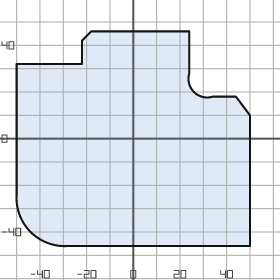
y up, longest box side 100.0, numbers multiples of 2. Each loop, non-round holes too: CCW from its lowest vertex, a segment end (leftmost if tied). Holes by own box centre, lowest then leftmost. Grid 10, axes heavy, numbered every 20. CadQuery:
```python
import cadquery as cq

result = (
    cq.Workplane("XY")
    .moveTo(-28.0, -46.0)
    .lineTo(50.0, -46.0)
    .lineTo(50.0, 10.0)
    .lineTo(44.0, 18.0)
    .lineTo(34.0, 18.0)
    .threePointArc((26.0, 20.0), (24.0, 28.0))
    .lineTo(24.0, 46.0)
    .lineTo(-18.0, 46.0)
    .lineTo(-22.0, 42.0)
    .lineTo(-22.0, 32.0)
    .lineTo(-50.0, 32.0)
    .lineTo(-50.0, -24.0)
    .threePointArc((-44.0, -40.0), (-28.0, -46.0))
    .close()
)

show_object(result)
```